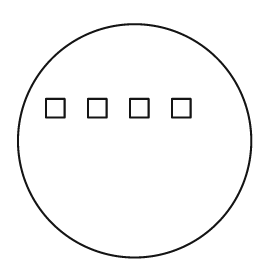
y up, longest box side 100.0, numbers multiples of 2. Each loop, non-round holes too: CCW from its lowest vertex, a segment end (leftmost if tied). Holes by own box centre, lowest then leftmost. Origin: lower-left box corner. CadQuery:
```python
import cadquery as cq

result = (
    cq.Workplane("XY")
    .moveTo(50.0, 50.0)
    .circle(50.0)
    .moveTo(12.0, 60.0)
    .lineTo(20.0, 60.0)
    .lineTo(20.0, 68.0)
    .lineTo(12.0, 68.0)
    .close()
    .moveTo(30.0, 60.0)
    .lineTo(38.0, 60.0)
    .lineTo(38.0, 68.0)
    .lineTo(30.0, 68.0)
    .close()
    .moveTo(48.0, 60.0)
    .lineTo(56.0, 60.0)
    .lineTo(56.0, 68.0)
    .lineTo(48.0, 68.0)
    .close()
    .moveTo(66.0, 60.0)
    .lineTo(74.0, 60.0)
    .lineTo(74.0, 68.0)
    .lineTo(66.0, 68.0)
    .close()
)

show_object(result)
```